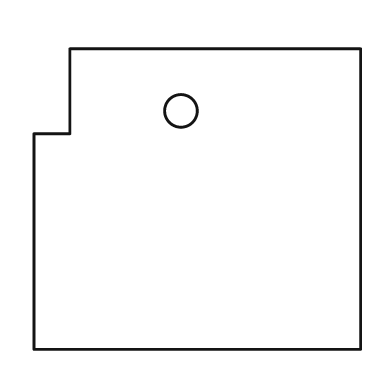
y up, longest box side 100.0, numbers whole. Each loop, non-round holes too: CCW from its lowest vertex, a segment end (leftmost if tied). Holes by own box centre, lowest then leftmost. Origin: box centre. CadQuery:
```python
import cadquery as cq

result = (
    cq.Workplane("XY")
    .moveTo(-50.0, -46.0)
    .lineTo(50.0, -46.0)
    .lineTo(50.0, 46.0)
    .lineTo(-39.0, 46.0)
    .lineTo(-39.0, 20.0)
    .lineTo(-50.0, 20.0)
    .close()
    .moveTo(-5.0, 27.0)
    .circle(5.0)
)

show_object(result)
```